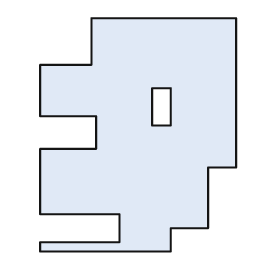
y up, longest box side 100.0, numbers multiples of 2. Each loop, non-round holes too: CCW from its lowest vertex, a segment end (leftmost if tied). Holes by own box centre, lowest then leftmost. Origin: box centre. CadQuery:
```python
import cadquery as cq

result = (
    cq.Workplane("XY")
    .moveTo(-42.0, -50.0)
    .lineTo(14.0, -50.0)
    .lineTo(14.0, -40.0)
    .lineTo(30.0, -40.0)
    .lineTo(30.0, -14.0)
    .lineTo(42.0, -14.0)
    .lineTo(42.0, 50.0)
    .lineTo(-20.0, 50.0)
    .lineTo(-20.0, 30.0)
    .lineTo(-42.0, 30.0)
    .lineTo(-42.0, 8.0)
    .lineTo(-18.0, 8.0)
    .lineTo(-18.0, -6.0)
    .lineTo(-42.0, -6.0)
    .lineTo(-42.0, -34.0)
    .lineTo(-8.0, -34.0)
    .lineTo(-8.0, -46.0)
    .lineTo(-42.0, -46.0)
    .close()
    .moveTo(6.0, 4.0)
    .lineTo(14.0, 4.0)
    .lineTo(14.0, 20.0)
    .lineTo(6.0, 20.0)
    .close()
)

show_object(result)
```